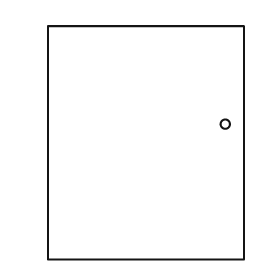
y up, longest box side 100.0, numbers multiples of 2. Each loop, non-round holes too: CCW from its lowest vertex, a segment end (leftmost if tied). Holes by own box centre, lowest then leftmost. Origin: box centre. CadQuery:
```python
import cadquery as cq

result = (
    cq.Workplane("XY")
    .moveTo(-42.0, -50.0)
    .lineTo(42.0, -50.0)
    .lineTo(42.0, 50.0)
    .lineTo(-42.0, 50.0)
    .close()
    .moveTo(34.0, 8.0)
    .circle(2.0)
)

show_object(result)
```